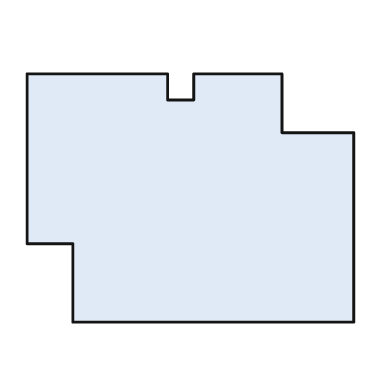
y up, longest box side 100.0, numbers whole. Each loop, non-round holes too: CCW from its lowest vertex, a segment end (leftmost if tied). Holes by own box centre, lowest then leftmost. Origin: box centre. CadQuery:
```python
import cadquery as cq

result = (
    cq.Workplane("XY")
    .moveTo(-36.0, -38.0)
    .lineTo(50.0, -38.0)
    .lineTo(50.0, 20.0)
    .lineTo(28.0, 20.0)
    .lineTo(28.0, 38.0)
    .lineTo(1.0, 38.0)
    .lineTo(1.0, 30.0)
    .lineTo(-7.0, 30.0)
    .lineTo(-7.0, 38.0)
    .lineTo(-50.0, 38.0)
    .lineTo(-50.0, -14.0)
    .lineTo(-36.0, -14.0)
    .close()
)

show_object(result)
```